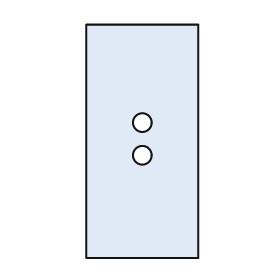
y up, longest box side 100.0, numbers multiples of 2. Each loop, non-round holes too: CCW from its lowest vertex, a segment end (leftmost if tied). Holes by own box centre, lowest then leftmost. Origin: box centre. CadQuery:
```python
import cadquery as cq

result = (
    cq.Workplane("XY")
    .moveTo(-24.0, -50.0)
    .lineTo(24.0, -50.0)
    .lineTo(24.0, 50.0)
    .lineTo(-24.0, 50.0)
    .close()
    .moveTo(0.0, -6.0)
    .circle(4.0)
    .moveTo(0.0, 8.0)
    .circle(4.0)
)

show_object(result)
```